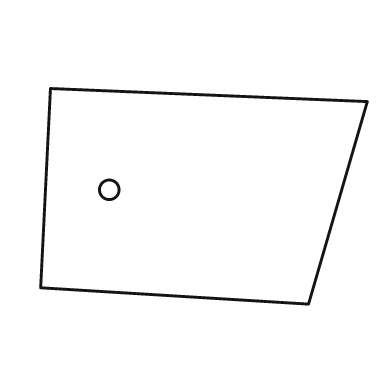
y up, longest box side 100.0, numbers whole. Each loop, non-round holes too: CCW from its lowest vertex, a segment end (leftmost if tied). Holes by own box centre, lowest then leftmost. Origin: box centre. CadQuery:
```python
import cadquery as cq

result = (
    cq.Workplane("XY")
    .moveTo(32.0, -33.0)
    .lineTo(50.0, 29.0)
    .lineTo(-47.0, 33.0)
    .lineTo(-50.0, -28.0)
    .close()
    .moveTo(-29.0, 2.0)
    .circle(3.0)
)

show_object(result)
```